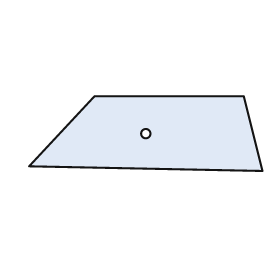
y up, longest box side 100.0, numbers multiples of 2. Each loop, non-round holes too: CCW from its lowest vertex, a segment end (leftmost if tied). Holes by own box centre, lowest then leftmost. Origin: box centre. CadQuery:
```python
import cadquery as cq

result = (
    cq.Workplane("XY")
    .moveTo(50.0, -16.0)
    .lineTo(42.0, 16.0)
    .lineTo(-22.0, 16.0)
    .lineTo(-50.0, -14.0)
    .close()
    .moveTo(0.0, 0.0)
    .circle(2.0)
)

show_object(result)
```